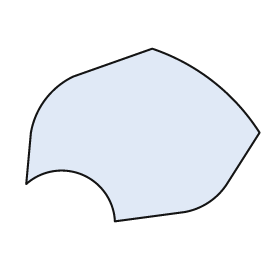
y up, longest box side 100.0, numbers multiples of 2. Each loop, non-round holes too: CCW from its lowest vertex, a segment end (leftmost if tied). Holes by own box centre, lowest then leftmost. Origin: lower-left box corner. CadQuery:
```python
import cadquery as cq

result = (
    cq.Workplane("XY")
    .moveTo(38.0, 0.0)
    .lineTo(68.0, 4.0)
    .threePointArc((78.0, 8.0), (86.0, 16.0))
    .lineTo(100.0, 38.0)
    .threePointArc((80.0, 60.0), (54.0, 74.0))
    .lineTo(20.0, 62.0)
    .threePointArc((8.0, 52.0), (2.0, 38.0))
    .lineTo(0.0, 16.0)
    .threePointArc((24.0, 20.0), (38.0, 0.0))
    .close()
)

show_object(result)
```